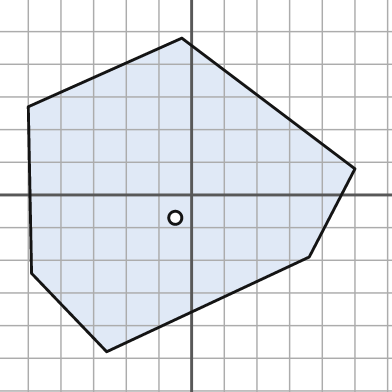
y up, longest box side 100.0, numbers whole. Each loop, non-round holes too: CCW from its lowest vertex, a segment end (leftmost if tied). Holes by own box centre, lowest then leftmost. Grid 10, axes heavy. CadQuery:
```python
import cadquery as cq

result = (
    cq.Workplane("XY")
    .moveTo(-26.0, -48.0)
    .lineTo(36.0, -19.0)
    .lineTo(50.0, 8.0)
    .lineTo(-3.0, 48.0)
    .lineTo(-50.0, 27.0)
    .lineTo(-49.0, -24.0)
    .close()
    .moveTo(-5.0, -7.0)
    .circle(2.0)
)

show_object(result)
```